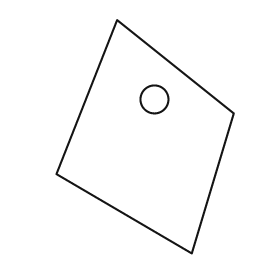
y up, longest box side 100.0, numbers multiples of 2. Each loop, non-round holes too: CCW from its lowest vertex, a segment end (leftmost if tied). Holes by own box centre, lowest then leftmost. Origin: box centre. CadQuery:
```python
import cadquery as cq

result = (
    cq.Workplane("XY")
    .moveTo(20.0, -50.0)
    .lineTo(38.0, 10.0)
    .lineTo(-12.0, 50.0)
    .lineTo(-38.0, -16.0)
    .close()
    .moveTo(4.0, 16.0)
    .circle(6.0)
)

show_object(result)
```